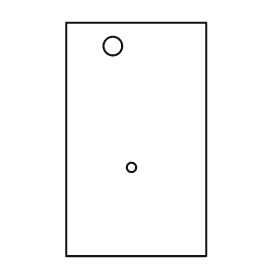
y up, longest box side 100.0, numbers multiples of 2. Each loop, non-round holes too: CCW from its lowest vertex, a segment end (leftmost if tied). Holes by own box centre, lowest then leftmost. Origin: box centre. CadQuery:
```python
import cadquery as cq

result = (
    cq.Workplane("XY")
    .moveTo(-30.0, -50.0)
    .lineTo(30.0, -50.0)
    .lineTo(30.0, 50.0)
    .lineTo(-30.0, 50.0)
    .close()
    .moveTo(-2.0, -12.0)
    .circle(2.0)
    .moveTo(-10.0, 40.0)
    .circle(4.0)
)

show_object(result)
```